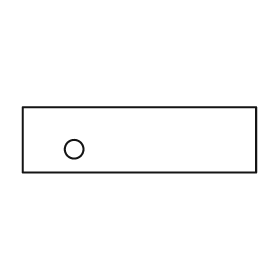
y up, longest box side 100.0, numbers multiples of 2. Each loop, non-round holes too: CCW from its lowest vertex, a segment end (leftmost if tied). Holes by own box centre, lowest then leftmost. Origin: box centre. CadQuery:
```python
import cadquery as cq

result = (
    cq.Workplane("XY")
    .moveTo(-50.0, -14.0)
    .lineTo(50.0, -14.0)
    .lineTo(50.0, 14.0)
    .lineTo(-50.0, 14.0)
    .close()
    .moveTo(-28.0, -4.0)
    .circle(4.0)
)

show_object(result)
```